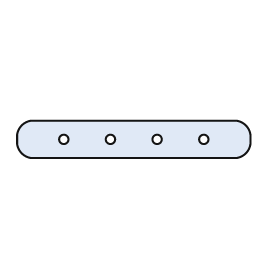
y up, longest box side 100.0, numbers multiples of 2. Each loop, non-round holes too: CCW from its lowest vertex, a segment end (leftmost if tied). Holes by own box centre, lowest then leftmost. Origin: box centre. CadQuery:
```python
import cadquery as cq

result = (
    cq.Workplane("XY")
    .moveTo(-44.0, -8.0)
    .lineTo(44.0, -8.0)
    .threePointArc((48.0, -6.0), (50.0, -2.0))
    .lineTo(50.0, 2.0)
    .threePointArc((48.0, 6.0), (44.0, 8.0))
    .lineTo(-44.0, 8.0)
    .threePointArc((-48.0, 6.0), (-50.0, 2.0))
    .lineTo(-50.0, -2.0)
    .threePointArc((-48.0, -6.0), (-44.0, -8.0))
    .close()
    .moveTo(-30.0, 0.0)
    .circle(2.0)
    .moveTo(-10.0, 0.0)
    .circle(2.0)
    .moveTo(10.0, 0.0)
    .circle(2.0)
    .moveTo(30.0, 0.0)
    .circle(2.0)
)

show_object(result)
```